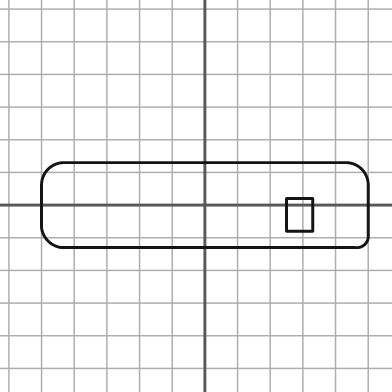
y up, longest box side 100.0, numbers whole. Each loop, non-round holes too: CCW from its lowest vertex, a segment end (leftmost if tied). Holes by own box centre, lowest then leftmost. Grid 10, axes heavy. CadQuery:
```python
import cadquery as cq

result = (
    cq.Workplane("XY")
    .moveTo(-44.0, -13.0)
    .lineTo(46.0, -13.0)
    .threePointArc((49.0, -12.0), (50.0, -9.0))
    .lineTo(50.0, 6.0)
    .threePointArc((48.0, 11.0), (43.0, 13.0))
    .lineTo(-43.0, 13.0)
    .threePointArc((-48.0, 11.0), (-50.0, 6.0))
    .lineTo(-50.0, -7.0)
    .threePointArc((-48.0, -11.0), (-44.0, -13.0))
    .close()
    .moveTo(25.0, -8.0)
    .lineTo(33.0, -8.0)
    .lineTo(33.0, 2.0)
    .lineTo(25.0, 2.0)
    .close()
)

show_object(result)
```